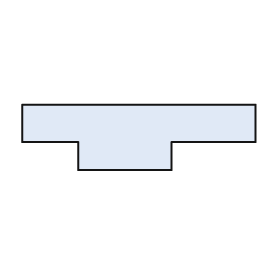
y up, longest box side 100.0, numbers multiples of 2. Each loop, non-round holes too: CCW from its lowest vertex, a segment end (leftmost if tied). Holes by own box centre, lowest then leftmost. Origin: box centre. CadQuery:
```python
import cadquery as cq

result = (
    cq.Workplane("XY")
    .moveTo(-26.0, -14.0)
    .lineTo(14.0, -14.0)
    .lineTo(14.0, -2.0)
    .lineTo(50.0, -2.0)
    .lineTo(50.0, 14.0)
    .lineTo(-50.0, 14.0)
    .lineTo(-50.0, -2.0)
    .lineTo(-26.0, -2.0)
    .close()
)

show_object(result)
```